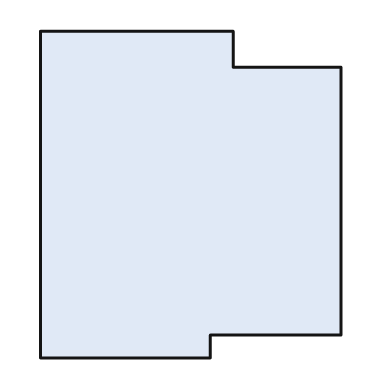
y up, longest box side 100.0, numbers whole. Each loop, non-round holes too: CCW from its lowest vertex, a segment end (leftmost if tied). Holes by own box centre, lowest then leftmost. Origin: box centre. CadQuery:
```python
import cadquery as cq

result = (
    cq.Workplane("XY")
    .moveTo(-46.0, -50.0)
    .lineTo(6.0, -50.0)
    .lineTo(6.0, -43.0)
    .lineTo(46.0, -43.0)
    .lineTo(46.0, 39.0)
    .lineTo(13.0, 39.0)
    .lineTo(13.0, 50.0)
    .lineTo(-46.0, 50.0)
    .close()
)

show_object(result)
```